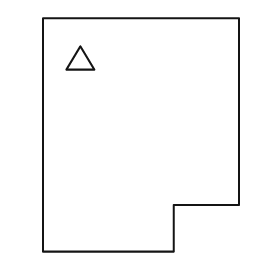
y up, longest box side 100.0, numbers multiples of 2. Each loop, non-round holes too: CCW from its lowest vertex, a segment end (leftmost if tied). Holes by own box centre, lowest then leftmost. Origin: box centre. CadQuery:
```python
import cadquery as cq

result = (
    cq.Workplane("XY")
    .moveTo(-42.0, -50.0)
    .lineTo(14.0, -50.0)
    .lineTo(14.0, -30.0)
    .lineTo(42.0, -30.0)
    .lineTo(42.0, 50.0)
    .lineTo(-42.0, 50.0)
    .close()
    .moveTo(-32.0, 28.0)
    .lineTo(-20.0, 28.0)
    .lineTo(-26.0, 38.0)
    .close()
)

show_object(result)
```